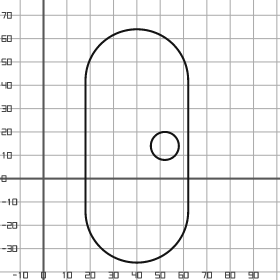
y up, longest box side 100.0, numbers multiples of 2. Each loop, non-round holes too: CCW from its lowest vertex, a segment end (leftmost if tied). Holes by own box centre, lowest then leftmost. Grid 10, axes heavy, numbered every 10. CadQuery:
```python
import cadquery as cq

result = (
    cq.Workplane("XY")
    .moveTo(18.0, -14.0)
    .threePointArc((40.0, -36.0), (62.0, -14.0))
    .lineTo(62.0, 42.0)
    .threePointArc((40.0, 64.0), (18.0, 42.0))
    .close()
    .moveTo(52.0, 14.0)
    .circle(6.0)
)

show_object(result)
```